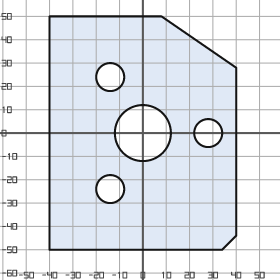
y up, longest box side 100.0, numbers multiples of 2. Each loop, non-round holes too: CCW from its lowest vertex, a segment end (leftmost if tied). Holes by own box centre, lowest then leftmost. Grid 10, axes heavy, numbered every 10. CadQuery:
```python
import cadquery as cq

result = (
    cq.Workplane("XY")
    .moveTo(-40.0, -50.0)
    .lineTo(34.0, -50.0)
    .lineTo(40.0, -44.0)
    .lineTo(40.0, 28.0)
    .lineTo(8.0, 50.0)
    .lineTo(-40.0, 50.0)
    .close()
    .moveTo(-14.0, -24.0)
    .circle(6.0)
    .moveTo(0.0, 0.0)
    .circle(12.0)
    .moveTo(28.0, 0.0)
    .circle(6.0)
    .moveTo(-14.0, 24.0)
    .circle(6.0)
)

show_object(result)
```